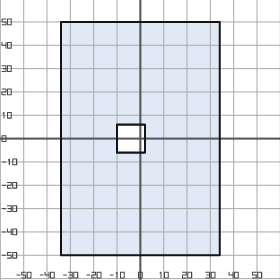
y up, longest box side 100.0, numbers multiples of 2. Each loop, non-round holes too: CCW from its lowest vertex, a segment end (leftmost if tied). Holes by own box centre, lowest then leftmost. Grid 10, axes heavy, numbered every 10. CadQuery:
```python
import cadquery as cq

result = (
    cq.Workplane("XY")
    .moveTo(-34.0, -50.0)
    .lineTo(34.0, -50.0)
    .lineTo(34.0, 50.0)
    .lineTo(-34.0, 50.0)
    .close()
    .moveTo(-10.0, -6.0)
    .lineTo(2.0, -6.0)
    .lineTo(2.0, 6.0)
    .lineTo(-10.0, 6.0)
    .close()
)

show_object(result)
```